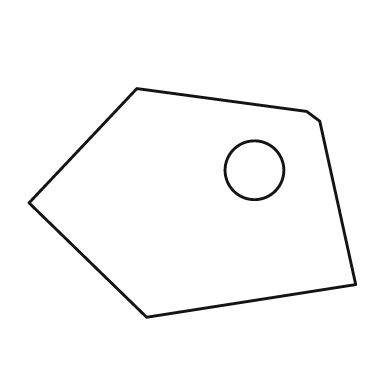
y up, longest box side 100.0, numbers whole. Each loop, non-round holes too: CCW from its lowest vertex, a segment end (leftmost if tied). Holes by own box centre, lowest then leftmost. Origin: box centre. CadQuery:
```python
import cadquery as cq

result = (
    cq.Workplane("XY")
    .moveTo(-14.0, -35.0)
    .lineTo(50.0, -25.0)
    .lineTo(39.0, 25.0)
    .lineTo(35.0, 28.0)
    .lineTo(-17.0, 35.0)
    .lineTo(-50.0, 0.0)
    .close()
    .moveTo(19.0, 10.0)
    .circle(9.0)
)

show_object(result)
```